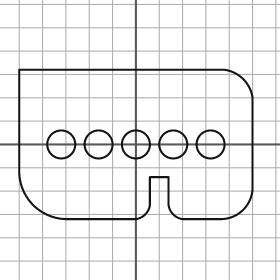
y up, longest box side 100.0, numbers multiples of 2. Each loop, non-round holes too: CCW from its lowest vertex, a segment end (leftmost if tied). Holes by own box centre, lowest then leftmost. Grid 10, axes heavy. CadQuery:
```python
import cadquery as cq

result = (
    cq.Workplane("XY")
    .moveTo(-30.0, -32.0)
    .lineTo(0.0, -32.0)
    .threePointArc((4.0, -30.0), (6.0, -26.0))
    .lineTo(6.0, -14.0)
    .lineTo(14.0, -14.0)
    .lineTo(14.0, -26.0)
    .threePointArc((16.0, -30.0), (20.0, -32.0))
    .lineTo(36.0, -32.0)
    .threePointArc((46.0, -28.0), (50.0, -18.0))
    .lineTo(50.0, 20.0)
    .threePointArc((46.0, 28.0), (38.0, 32.0))
    .lineTo(-50.0, 32.0)
    .lineTo(-50.0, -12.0)
    .threePointArc((-44.0, -26.0), (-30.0, -32.0))
    .close()
    .moveTo(-32.0, 0.0)
    .circle(6.0)
    .moveTo(-16.0, 0.0)
    .circle(6.0)
    .moveTo(0.0, 0.0)
    .circle(6.0)
    .moveTo(16.0, 0.0)
    .circle(6.0)
    .moveTo(32.0, 0.0)
    .circle(6.0)
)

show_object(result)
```